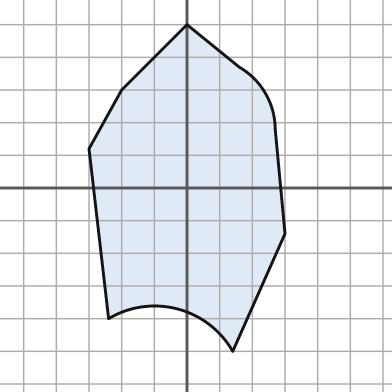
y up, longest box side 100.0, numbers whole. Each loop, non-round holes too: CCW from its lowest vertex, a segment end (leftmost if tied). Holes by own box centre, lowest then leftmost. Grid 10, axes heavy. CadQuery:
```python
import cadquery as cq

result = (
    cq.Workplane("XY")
    .moveTo(14.0, -50.0)
    .lineTo(30.0, -14.0)
    .lineTo(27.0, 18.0)
    .threePointArc((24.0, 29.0), (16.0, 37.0))
    .lineTo(0.0, 50.0)
    .lineTo(-20.0, 30.0)
    .lineTo(-30.0, 12.0)
    .lineTo(-24.0, -40.0)
    .threePointArc((-3.0, -37.0), (14.0, -50.0))
    .close()
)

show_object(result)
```